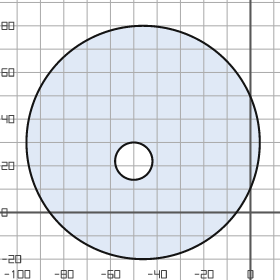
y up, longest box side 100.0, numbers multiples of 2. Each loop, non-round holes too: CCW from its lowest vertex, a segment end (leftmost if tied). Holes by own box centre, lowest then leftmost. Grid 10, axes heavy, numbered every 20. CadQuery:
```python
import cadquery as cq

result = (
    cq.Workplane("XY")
    .moveTo(-46.0, 30.0)
    .circle(50.0)
    .moveTo(-50.0, 22.0)
    .circle(8.0)
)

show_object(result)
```